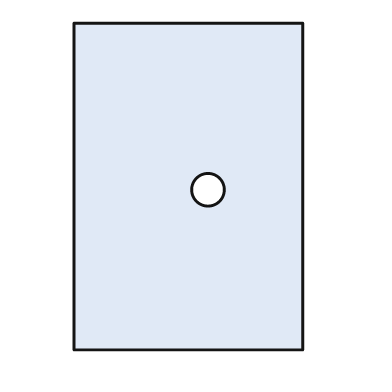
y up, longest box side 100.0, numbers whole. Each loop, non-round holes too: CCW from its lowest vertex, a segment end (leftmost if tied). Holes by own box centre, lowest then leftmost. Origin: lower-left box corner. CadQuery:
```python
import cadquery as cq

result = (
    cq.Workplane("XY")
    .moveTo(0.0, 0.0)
    .lineTo(70.0, 0.0)
    .lineTo(70.0, 100.0)
    .lineTo(0.0, 100.0)
    .close()
    .moveTo(41.0, 49.0)
    .circle(5.0)
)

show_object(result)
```